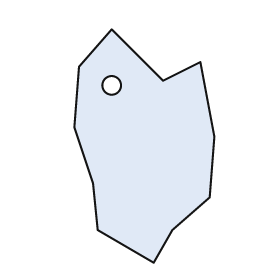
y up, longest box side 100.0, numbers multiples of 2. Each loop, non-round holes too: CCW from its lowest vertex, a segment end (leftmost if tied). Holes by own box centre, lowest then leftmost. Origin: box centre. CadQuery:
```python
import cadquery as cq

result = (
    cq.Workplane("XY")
    .moveTo(4.0, -50.0)
    .lineTo(12.0, -36.0)
    .lineTo(28.0, -22.0)
    .lineTo(30.0, 4.0)
    .lineTo(24.0, 36.0)
    .lineTo(8.0, 28.0)
    .lineTo(-14.0, 50.0)
    .lineTo(-28.0, 34.0)
    .lineTo(-30.0, 8.0)
    .lineTo(-22.0, -16.0)
    .lineTo(-20.0, -36.0)
    .close()
    .moveTo(-14.0, 26.0)
    .circle(4.0)
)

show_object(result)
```